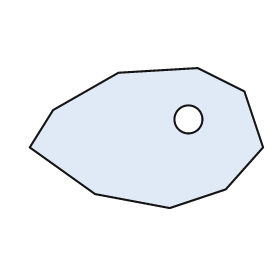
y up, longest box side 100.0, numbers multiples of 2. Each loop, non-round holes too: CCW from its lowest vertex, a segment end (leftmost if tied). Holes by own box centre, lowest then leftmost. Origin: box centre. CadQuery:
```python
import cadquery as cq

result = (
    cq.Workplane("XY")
    .moveTo(10.0, -30.0)
    .lineTo(34.0, -22.0)
    .lineTo(50.0, -4.0)
    .lineTo(42.0, 20.0)
    .lineTo(22.0, 30.0)
    .lineTo(-12.0, 28.0)
    .lineTo(-40.0, 12.0)
    .lineTo(-50.0, -4.0)
    .lineTo(-22.0, -24.0)
    .close()
    .moveTo(18.0, 8.0)
    .circle(6.0)
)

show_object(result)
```